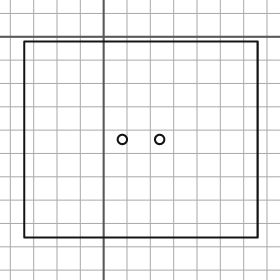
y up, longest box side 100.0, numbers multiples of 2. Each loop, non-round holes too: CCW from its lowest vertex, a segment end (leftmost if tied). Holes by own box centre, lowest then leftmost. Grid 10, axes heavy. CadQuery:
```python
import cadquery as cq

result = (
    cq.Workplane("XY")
    .moveTo(-34.0, -86.0)
    .lineTo(66.0, -86.0)
    .lineTo(66.0, -2.0)
    .lineTo(-34.0, -2.0)
    .close()
    .moveTo(8.0, -44.0)
    .circle(2.0)
    .moveTo(24.0, -44.0)
    .circle(2.0)
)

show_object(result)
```